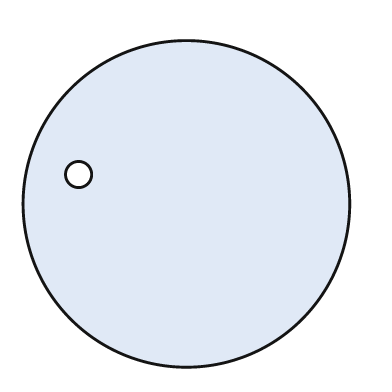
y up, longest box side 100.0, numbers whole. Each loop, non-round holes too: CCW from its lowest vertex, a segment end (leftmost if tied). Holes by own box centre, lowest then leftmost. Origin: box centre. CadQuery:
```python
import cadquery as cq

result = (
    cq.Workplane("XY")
    .moveTo(0.0, 0.0)
    .circle(50.0)
    .moveTo(-33.0, 9.0)
    .circle(4.0)
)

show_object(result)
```